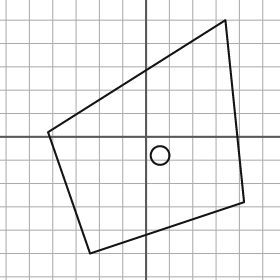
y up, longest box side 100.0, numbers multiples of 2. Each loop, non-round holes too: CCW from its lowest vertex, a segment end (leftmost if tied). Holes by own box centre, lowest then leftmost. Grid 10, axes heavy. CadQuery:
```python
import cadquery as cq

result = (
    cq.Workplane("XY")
    .moveTo(-24.0, -50.0)
    .lineTo(42.0, -28.0)
    .lineTo(34.0, 50.0)
    .lineTo(-42.0, 2.0)
    .close()
    .moveTo(6.0, -8.0)
    .circle(4.0)
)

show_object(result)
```